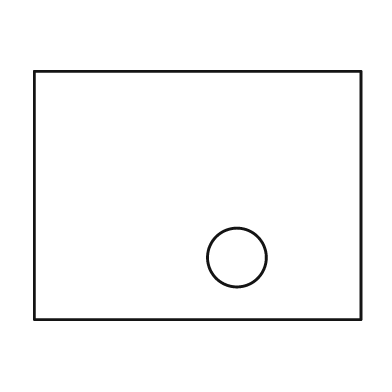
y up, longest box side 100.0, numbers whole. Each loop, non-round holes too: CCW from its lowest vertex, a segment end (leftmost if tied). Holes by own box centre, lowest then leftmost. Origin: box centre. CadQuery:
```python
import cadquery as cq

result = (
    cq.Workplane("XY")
    .moveTo(-50.0, -38.0)
    .lineTo(50.0, -38.0)
    .lineTo(50.0, 38.0)
    .lineTo(-50.0, 38.0)
    .close()
    .moveTo(12.0, -19.0)
    .circle(9.0)
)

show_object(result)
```